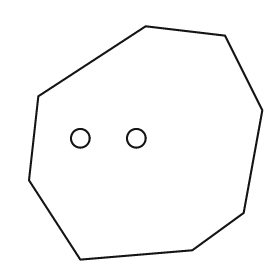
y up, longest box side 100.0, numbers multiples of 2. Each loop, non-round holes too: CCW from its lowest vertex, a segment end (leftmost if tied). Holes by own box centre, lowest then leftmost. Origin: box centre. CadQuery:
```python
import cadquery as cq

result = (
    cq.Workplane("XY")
    .moveTo(-28.0, -50.0)
    .lineTo(20.0, -46.0)
    .lineTo(42.0, -30.0)
    .lineTo(50.0, 14.0)
    .lineTo(34.0, 46.0)
    .lineTo(0.0, 50.0)
    .lineTo(-46.0, 20.0)
    .lineTo(-50.0, -16.0)
    .close()
    .moveTo(-28.0, 2.0)
    .circle(4.0)
    .moveTo(-4.0, 2.0)
    .circle(4.0)
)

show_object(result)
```